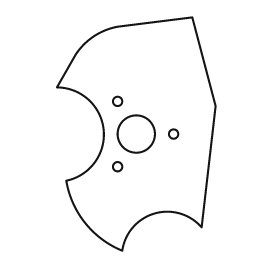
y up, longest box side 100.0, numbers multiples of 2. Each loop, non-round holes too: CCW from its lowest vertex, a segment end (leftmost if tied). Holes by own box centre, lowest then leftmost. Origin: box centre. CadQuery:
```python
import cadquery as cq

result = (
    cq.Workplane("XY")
    .moveTo(-6.0, -50.0)
    .threePointArc((8.0, -34.0), (28.0, -40.0))
    .lineTo(34.0, 12.0)
    .lineTo(24.0, 50.0)
    .lineTo(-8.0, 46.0)
    .threePointArc((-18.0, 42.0), (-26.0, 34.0))
    .lineTo(-34.0, 20.0)
    .threePointArc((-14.0, 2.0), (-30.0, -20.0))
    .threePointArc((-22.0, -38.0), (-6.0, -50.0))
    .close()
    .moveTo(-8.0, -14.0)
    .circle(2.0)
    .moveTo(0.0, 0.0)
    .circle(8.0)
    .moveTo(16.0, 0.0)
    .circle(2.0)
    .moveTo(-8.0, 14.0)
    .circle(2.0)
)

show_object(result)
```